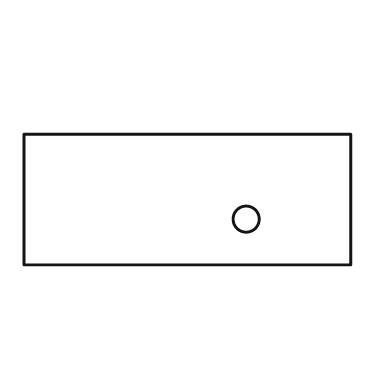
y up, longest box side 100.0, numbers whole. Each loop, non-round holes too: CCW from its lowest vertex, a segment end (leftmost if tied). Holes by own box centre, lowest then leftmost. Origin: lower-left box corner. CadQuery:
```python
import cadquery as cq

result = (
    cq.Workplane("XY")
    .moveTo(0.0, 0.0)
    .lineTo(100.0, 0.0)
    .lineTo(100.0, 40.0)
    .lineTo(0.0, 40.0)
    .close()
    .moveTo(68.0, 14.0)
    .circle(4.0)
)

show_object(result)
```